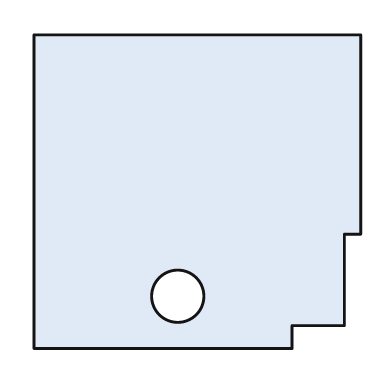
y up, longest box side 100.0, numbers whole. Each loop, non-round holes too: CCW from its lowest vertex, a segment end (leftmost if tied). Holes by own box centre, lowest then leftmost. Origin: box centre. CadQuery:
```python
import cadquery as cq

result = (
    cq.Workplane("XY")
    .moveTo(-50.0, -48.0)
    .lineTo(29.0, -48.0)
    .lineTo(29.0, -41.0)
    .lineTo(45.0, -41.0)
    .lineTo(45.0, -13.0)
    .lineTo(50.0, -13.0)
    .lineTo(50.0, 48.0)
    .lineTo(-50.0, 48.0)
    .close()
    .moveTo(-6.0, -32.0)
    .circle(8.0)
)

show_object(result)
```